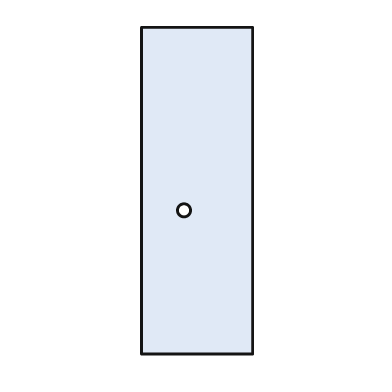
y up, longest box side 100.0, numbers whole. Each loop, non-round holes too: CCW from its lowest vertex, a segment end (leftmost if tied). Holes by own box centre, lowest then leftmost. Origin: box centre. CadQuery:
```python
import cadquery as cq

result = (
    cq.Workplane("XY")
    .moveTo(-17.0, -50.0)
    .lineTo(17.0, -50.0)
    .lineTo(17.0, 50.0)
    .lineTo(-17.0, 50.0)
    .close()
    .moveTo(-4.0, -6.0)
    .circle(2.0)
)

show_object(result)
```